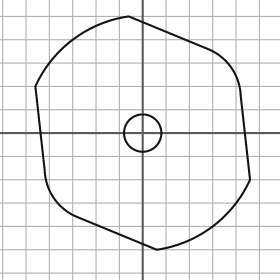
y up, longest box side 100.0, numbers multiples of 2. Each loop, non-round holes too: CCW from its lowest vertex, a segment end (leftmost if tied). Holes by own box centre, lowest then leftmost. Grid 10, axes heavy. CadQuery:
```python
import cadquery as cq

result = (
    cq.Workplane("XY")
    .moveTo(6.0, -50.0)
    .threePointArc((30.0, -40.0), (46.0, -20.0))
    .lineTo(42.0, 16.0)
    .threePointArc((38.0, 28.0), (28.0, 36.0))
    .lineTo(-6.0, 50.0)
    .threePointArc((-30.0, 40.0), (-46.0, 20.0))
    .lineTo(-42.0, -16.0)
    .threePointArc((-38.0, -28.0), (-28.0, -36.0))
    .close()
    .moveTo(0.0, 0.0)
    .circle(8.0)
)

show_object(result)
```